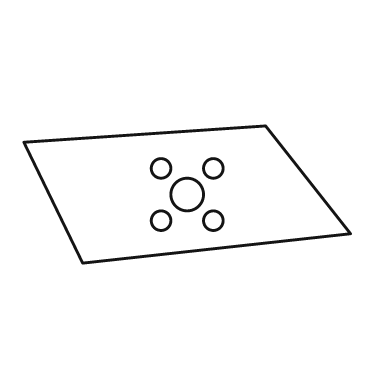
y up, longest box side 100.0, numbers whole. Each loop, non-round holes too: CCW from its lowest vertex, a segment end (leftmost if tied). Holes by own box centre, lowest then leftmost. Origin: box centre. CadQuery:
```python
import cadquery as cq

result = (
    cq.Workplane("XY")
    .moveTo(-32.0, -21.0)
    .lineTo(50.0, -12.0)
    .lineTo(24.0, 21.0)
    .lineTo(-50.0, 16.0)
    .close()
    .moveTo(-8.0, -8.0)
    .circle(3.0)
    .moveTo(8.0, -8.0)
    .circle(3.0)
    .moveTo(0.0, 0.0)
    .circle(5.0)
    .moveTo(-8.0, 8.0)
    .circle(3.0)
    .moveTo(8.0, 8.0)
    .circle(3.0)
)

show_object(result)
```